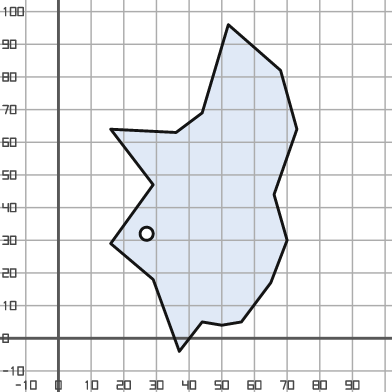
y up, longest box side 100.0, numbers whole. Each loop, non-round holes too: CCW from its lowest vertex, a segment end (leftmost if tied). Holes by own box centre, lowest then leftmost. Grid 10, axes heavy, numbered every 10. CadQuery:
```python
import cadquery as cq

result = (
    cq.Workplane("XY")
    .moveTo(37.0, -4.0)
    .lineTo(44.0, 5.0)
    .lineTo(50.0, 4.0)
    .lineTo(56.0, 5.0)
    .lineTo(65.0, 17.0)
    .lineTo(70.0, 30.0)
    .lineTo(66.0, 44.0)
    .lineTo(73.0, 64.0)
    .lineTo(68.0, 82.0)
    .lineTo(52.0, 96.0)
    .lineTo(44.0, 69.0)
    .lineTo(36.0, 63.0)
    .lineTo(16.0, 64.0)
    .lineTo(29.0, 47.0)
    .lineTo(16.0, 29.0)
    .lineTo(29.0, 18.0)
    .close()
    .moveTo(27.0, 32.0)
    .circle(2.0)
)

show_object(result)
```